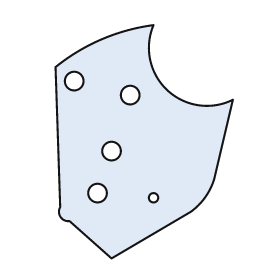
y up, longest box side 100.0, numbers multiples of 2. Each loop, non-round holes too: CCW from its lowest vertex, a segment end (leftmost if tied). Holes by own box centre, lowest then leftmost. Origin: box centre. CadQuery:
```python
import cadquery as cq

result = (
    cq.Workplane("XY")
    .moveTo(-14.0, -50.0)
    .lineTo(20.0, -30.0)
    .threePointArc((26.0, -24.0), (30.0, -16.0))
    .lineTo(38.0, 18.0)
    .threePointArc((10.0, 22.0), (4.0, 50.0))
    .threePointArc((-18.0, 44.0), (-38.0, 32.0))
    .lineTo(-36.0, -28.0)
    .threePointArc((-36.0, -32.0), (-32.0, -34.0))
    .close()
    .moveTo(4.0, -24.0)
    .circle(2.0)
    .moveTo(-20.0, -22.0)
    .circle(4.0)
    .moveTo(-14.0, -4.0)
    .circle(4.0)
    .moveTo(-6.0, 20.0)
    .circle(4.0)
    .moveTo(-30.0, 26.0)
    .circle(4.0)
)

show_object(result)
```